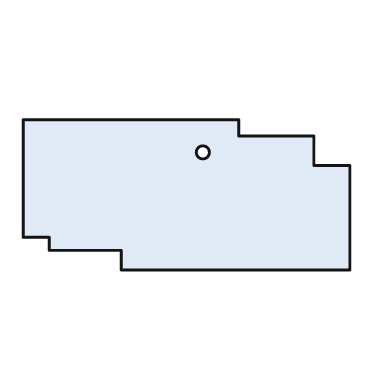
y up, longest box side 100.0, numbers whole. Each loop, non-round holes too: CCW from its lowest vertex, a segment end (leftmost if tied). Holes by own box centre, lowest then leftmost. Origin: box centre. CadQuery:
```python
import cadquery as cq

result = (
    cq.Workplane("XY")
    .moveTo(-20.0, -23.0)
    .lineTo(50.0, -23.0)
    .lineTo(50.0, 9.0)
    .lineTo(39.0, 9.0)
    .lineTo(39.0, 18.0)
    .lineTo(16.0, 18.0)
    .lineTo(16.0, 23.0)
    .lineTo(-50.0, 23.0)
    .lineTo(-50.0, -13.0)
    .lineTo(-42.0, -13.0)
    .lineTo(-42.0, -17.0)
    .lineTo(-20.0, -17.0)
    .close()
    .moveTo(5.0, 13.0)
    .circle(2.0)
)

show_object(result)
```